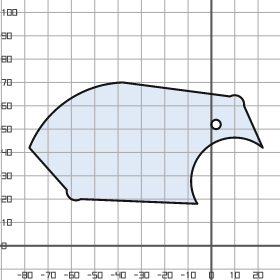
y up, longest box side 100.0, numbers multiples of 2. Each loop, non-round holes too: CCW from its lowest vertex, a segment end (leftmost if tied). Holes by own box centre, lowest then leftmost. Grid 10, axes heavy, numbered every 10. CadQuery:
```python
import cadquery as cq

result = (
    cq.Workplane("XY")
    .moveTo(-6.0, 18.0)
    .threePointArc((-2.0, 42.0), (22.0, 42.0))
    .lineTo(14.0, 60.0)
    .threePointArc((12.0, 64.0), (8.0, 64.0))
    .lineTo(-38.0, 70.0)
    .threePointArc((-62.0, 62.0), (-78.0, 42.0))
    .lineTo(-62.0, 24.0)
    .threePointArc((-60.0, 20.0), (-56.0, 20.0))
    .close()
    .moveTo(2.0, 52.0)
    .circle(2.0)
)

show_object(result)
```